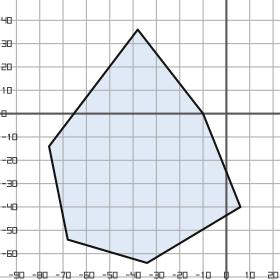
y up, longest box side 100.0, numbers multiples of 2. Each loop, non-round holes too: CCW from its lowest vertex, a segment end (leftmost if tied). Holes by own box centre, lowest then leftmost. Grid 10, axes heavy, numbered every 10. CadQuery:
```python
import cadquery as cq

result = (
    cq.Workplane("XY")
    .moveTo(-34.0, -64.0)
    .lineTo(6.0, -40.0)
    .lineTo(-10.0, 0.0)
    .lineTo(-38.0, 36.0)
    .lineTo(-76.0, -14.0)
    .lineTo(-68.0, -54.0)
    .close()
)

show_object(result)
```